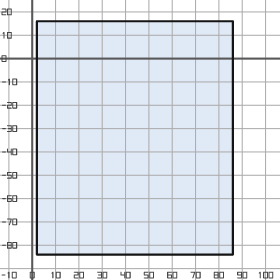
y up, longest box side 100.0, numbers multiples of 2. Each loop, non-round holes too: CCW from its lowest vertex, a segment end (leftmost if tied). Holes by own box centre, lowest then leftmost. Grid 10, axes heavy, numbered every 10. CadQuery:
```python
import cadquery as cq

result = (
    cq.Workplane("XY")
    .moveTo(2.0, -84.0)
    .lineTo(86.0, -84.0)
    .lineTo(86.0, 16.0)
    .lineTo(2.0, 16.0)
    .close()
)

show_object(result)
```